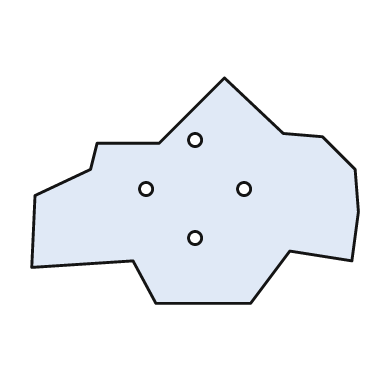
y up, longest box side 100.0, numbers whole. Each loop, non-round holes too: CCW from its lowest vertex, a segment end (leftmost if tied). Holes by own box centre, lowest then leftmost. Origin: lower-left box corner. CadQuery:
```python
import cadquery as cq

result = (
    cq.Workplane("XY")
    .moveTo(38.0, 0.0)
    .lineTo(67.0, 0.0)
    .lineTo(79.0, 16.0)
    .lineTo(98.0, 13.0)
    .lineTo(100.0, 28.0)
    .lineTo(99.0, 41.0)
    .lineTo(89.0, 51.0)
    .lineTo(77.0, 52.0)
    .lineTo(59.0, 69.0)
    .lineTo(39.0, 49.0)
    .lineTo(20.0, 49.0)
    .lineTo(18.0, 41.0)
    .lineTo(1.0, 33.0)
    .lineTo(0.0, 11.0)
    .lineTo(31.0, 13.0)
    .close()
    .moveTo(50.0, 20.0)
    .circle(2.0)
    .moveTo(35.0, 35.0)
    .circle(2.0)
    .moveTo(65.0, 35.0)
    .circle(2.0)
    .moveTo(50.0, 50.0)
    .circle(2.0)
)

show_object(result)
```